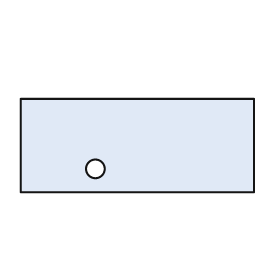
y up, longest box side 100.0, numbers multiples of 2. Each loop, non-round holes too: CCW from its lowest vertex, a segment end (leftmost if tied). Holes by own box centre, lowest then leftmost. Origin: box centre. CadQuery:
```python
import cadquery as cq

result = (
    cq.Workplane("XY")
    .moveTo(-50.0, -20.0)
    .lineTo(50.0, -20.0)
    .lineTo(50.0, 20.0)
    .lineTo(-50.0, 20.0)
    .close()
    .moveTo(-18.0, -10.0)
    .circle(4.0)
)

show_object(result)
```